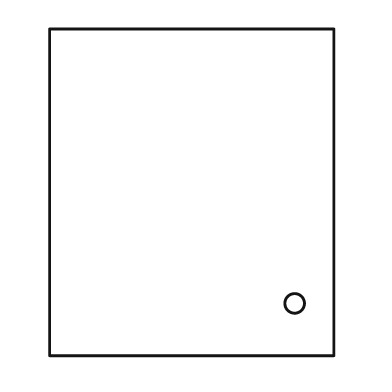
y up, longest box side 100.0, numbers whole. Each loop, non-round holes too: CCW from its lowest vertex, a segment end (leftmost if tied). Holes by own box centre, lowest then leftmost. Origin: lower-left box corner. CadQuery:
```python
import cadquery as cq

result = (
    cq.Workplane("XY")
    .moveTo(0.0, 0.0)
    .lineTo(87.0, 0.0)
    .lineTo(87.0, 100.0)
    .lineTo(0.0, 100.0)
    .close()
    .moveTo(75.0, 16.0)
    .circle(3.0)
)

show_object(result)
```